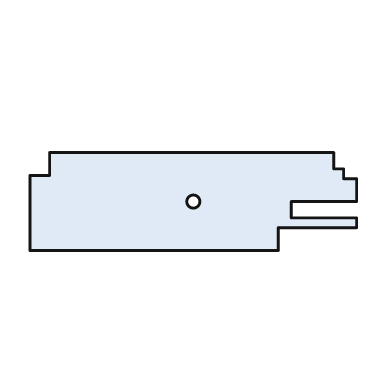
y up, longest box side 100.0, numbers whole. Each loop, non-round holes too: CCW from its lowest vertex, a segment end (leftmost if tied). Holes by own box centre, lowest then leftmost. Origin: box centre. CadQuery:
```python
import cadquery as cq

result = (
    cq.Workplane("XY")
    .moveTo(-50.0, -15.0)
    .lineTo(26.0, -15.0)
    .lineTo(26.0, -8.0)
    .lineTo(50.0, -8.0)
    .lineTo(50.0, -5.0)
    .lineTo(30.0, -5.0)
    .lineTo(30.0, 0.0)
    .lineTo(50.0, 0.0)
    .lineTo(50.0, 7.0)
    .lineTo(46.0, 7.0)
    .lineTo(46.0, 10.0)
    .lineTo(43.0, 10.0)
    .lineTo(43.0, 15.0)
    .lineTo(-44.0, 15.0)
    .lineTo(-44.0, 8.0)
    .lineTo(-50.0, 8.0)
    .close()
    .moveTo(0.0, 0.0)
    .circle(2.0)
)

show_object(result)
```